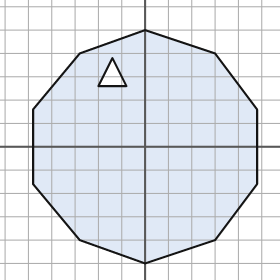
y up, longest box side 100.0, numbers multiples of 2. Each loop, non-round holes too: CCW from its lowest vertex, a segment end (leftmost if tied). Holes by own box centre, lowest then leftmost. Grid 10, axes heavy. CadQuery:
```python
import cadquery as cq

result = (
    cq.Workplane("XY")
    .moveTo(0.0, -50.0)
    .lineTo(30.0, -40.0)
    .lineTo(48.0, -16.0)
    .lineTo(48.0, 16.0)
    .lineTo(30.0, 40.0)
    .lineTo(0.0, 50.0)
    .lineTo(-28.0, 40.0)
    .lineTo(-48.0, 16.0)
    .lineTo(-48.0, -16.0)
    .lineTo(-28.0, -40.0)
    .close()
    .moveTo(-20.0, 26.0)
    .lineTo(-8.0, 26.0)
    .lineTo(-14.0, 38.0)
    .close()
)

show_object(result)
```